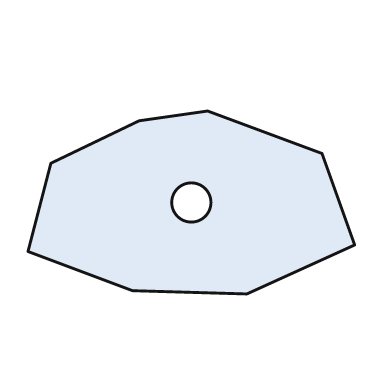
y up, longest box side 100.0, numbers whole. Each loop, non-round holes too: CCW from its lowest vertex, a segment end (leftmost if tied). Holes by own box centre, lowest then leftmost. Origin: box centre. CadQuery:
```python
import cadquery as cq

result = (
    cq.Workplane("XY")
    .moveTo(17.0, -28.0)
    .lineTo(50.0, -13.0)
    .lineTo(40.0, 15.0)
    .lineTo(5.0, 28.0)
    .lineTo(-16.0, 25.0)
    .lineTo(-43.0, 12.0)
    .lineTo(-50.0, -15.0)
    .lineTo(-18.0, -27.0)
    .close()
    .moveTo(0.0, 0.0)
    .circle(6.0)
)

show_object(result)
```